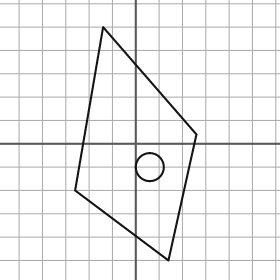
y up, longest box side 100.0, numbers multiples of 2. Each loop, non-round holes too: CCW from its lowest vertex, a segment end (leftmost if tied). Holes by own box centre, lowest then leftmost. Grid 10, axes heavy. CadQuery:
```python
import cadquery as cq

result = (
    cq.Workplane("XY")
    .moveTo(14.0, -50.0)
    .lineTo(26.0, 4.0)
    .lineTo(-14.0, 50.0)
    .lineTo(-26.0, -20.0)
    .close()
    .moveTo(6.0, -10.0)
    .circle(6.0)
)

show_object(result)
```